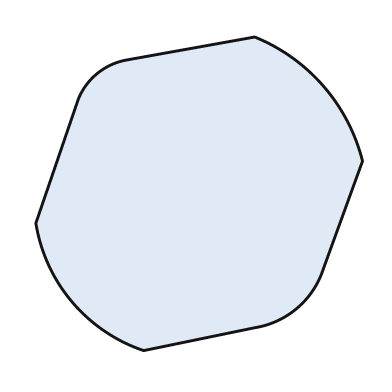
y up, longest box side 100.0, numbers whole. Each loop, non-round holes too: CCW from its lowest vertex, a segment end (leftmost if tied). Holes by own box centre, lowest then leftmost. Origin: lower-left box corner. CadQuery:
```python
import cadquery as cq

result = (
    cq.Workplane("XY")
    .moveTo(33.0, 0.0)
    .lineTo(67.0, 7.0)
    .threePointArc((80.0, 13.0), (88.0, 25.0))
    .lineTo(100.0, 58.0)
    .threePointArc((88.0, 81.0), (67.0, 96.0))
    .lineTo(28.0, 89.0)
    .threePointArc((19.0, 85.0), (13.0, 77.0))
    .lineTo(0.0, 39.0)
    .threePointArc((11.0, 15.0), (33.0, 0.0))
    .close()
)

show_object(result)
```